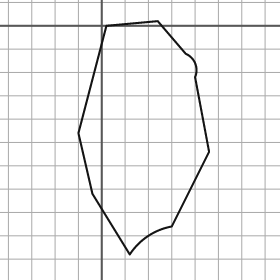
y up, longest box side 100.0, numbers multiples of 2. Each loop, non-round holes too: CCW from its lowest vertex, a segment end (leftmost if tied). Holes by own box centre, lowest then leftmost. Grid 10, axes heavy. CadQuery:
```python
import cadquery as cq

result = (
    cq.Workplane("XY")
    .moveTo(12.0, -98.0)
    .threePointArc((20.0, -90.0), (30.0, -86.0))
    .lineTo(46.0, -54.0)
    .lineTo(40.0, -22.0)
    .threePointArc((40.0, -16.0), (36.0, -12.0))
    .lineTo(24.0, 2.0)
    .lineTo(2.0, 0.0)
    .lineTo(-10.0, -46.0)
    .lineTo(-4.0, -72.0)
    .close()
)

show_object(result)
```